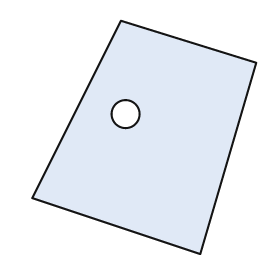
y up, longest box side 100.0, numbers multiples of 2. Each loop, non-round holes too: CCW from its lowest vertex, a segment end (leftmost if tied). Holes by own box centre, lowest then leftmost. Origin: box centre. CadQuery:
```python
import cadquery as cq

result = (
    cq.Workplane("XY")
    .moveTo(24.0, -50.0)
    .lineTo(48.0, 32.0)
    .lineTo(-10.0, 50.0)
    .lineTo(-48.0, -26.0)
    .close()
    .moveTo(-8.0, 10.0)
    .circle(6.0)
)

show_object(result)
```